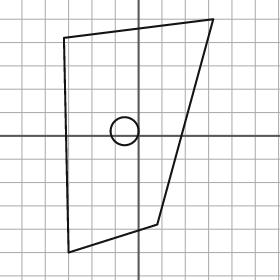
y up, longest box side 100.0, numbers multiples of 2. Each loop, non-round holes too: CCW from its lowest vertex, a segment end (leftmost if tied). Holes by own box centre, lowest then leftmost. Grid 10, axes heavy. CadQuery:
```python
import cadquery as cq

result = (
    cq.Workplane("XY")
    .moveTo(-30.0, -50.0)
    .lineTo(8.0, -38.0)
    .lineTo(32.0, 50.0)
    .lineTo(-32.0, 42.0)
    .close()
    .moveTo(-6.0, 2.0)
    .circle(6.0)
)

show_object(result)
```